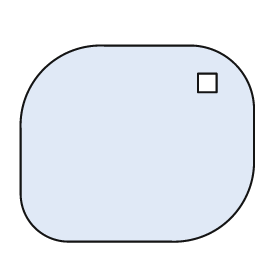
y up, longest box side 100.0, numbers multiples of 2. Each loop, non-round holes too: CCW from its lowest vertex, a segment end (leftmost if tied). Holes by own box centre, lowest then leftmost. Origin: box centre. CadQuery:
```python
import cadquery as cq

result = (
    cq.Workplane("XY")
    .moveTo(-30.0, -42.0)
    .lineTo(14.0, -42.0)
    .threePointArc((40.0, -32.0), (50.0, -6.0))
    .lineTo(50.0, 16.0)
    .threePointArc((42.0, 34.0), (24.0, 42.0))
    .lineTo(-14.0, 42.0)
    .threePointArc((-40.0, 32.0), (-50.0, 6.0))
    .lineTo(-50.0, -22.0)
    .threePointArc((-44.0, -36.0), (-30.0, -42.0))
    .close()
    .moveTo(26.0, 22.0)
    .lineTo(34.0, 22.0)
    .lineTo(34.0, 30.0)
    .lineTo(26.0, 30.0)
    .close()
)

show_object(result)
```